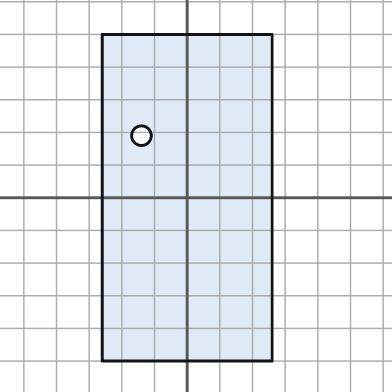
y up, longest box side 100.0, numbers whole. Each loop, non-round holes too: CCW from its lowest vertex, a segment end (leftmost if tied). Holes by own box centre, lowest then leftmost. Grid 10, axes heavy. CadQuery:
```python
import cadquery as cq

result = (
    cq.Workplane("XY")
    .moveTo(-26.0, -50.0)
    .lineTo(26.0, -50.0)
    .lineTo(26.0, 50.0)
    .lineTo(-26.0, 50.0)
    .close()
    .moveTo(-14.0, 19.0)
    .circle(3.0)
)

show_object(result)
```